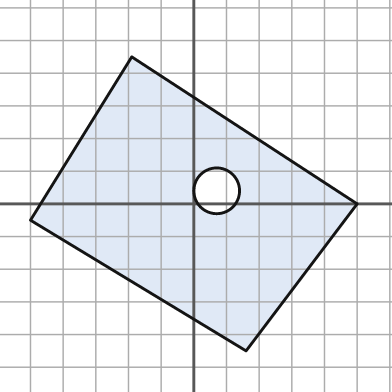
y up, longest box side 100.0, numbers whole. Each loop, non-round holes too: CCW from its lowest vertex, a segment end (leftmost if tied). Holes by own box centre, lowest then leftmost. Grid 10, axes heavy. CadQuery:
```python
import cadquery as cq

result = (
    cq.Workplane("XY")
    .moveTo(16.0, -45.0)
    .lineTo(50.0, 0.0)
    .lineTo(-19.0, 45.0)
    .lineTo(-50.0, -5.0)
    .close()
    .moveTo(7.0, 4.0)
    .circle(7.0)
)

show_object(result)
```